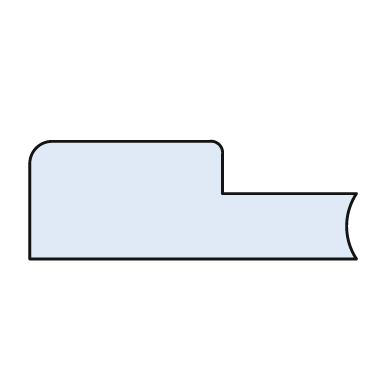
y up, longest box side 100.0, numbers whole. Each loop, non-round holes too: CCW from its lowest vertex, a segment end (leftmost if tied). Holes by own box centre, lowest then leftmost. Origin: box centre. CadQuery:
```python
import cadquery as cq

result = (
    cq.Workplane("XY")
    .moveTo(-50.0, -18.0)
    .lineTo(50.0, -18.0)
    .threePointArc((47.0, -8.0), (50.0, 2.0))
    .lineTo(9.0, 2.0)
    .lineTo(9.0, 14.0)
    .threePointArc((8.0, 17.0), (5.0, 18.0))
    .lineTo(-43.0, 18.0)
    .threePointArc((-48.0, 16.0), (-50.0, 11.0))
    .close()
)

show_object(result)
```